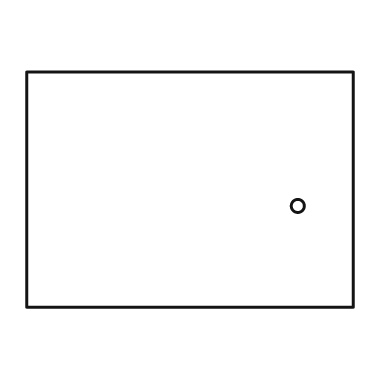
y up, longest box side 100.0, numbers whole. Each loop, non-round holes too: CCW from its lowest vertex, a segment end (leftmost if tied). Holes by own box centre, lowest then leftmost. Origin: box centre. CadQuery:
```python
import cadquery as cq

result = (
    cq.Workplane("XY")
    .moveTo(-50.0, -36.0)
    .lineTo(50.0, -36.0)
    .lineTo(50.0, 36.0)
    .lineTo(-50.0, 36.0)
    .close()
    .moveTo(33.0, -5.0)
    .circle(2.0)
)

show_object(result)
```